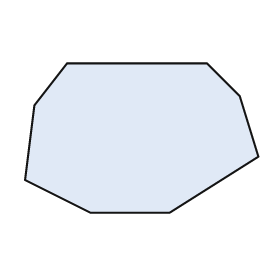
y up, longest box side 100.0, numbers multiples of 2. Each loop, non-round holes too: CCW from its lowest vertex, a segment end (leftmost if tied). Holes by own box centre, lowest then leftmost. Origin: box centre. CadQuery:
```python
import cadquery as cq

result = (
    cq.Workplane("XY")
    .moveTo(-22.0, -32.0)
    .lineTo(12.0, -32.0)
    .lineTo(50.0, -8.0)
    .lineTo(42.0, 18.0)
    .lineTo(28.0, 32.0)
    .lineTo(-32.0, 32.0)
    .lineTo(-46.0, 14.0)
    .lineTo(-50.0, -18.0)
    .close()
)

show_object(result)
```